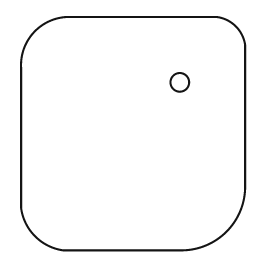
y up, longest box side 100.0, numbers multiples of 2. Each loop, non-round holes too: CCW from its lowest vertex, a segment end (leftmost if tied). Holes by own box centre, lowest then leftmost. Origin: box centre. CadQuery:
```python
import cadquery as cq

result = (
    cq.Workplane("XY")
    .moveTo(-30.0, -50.0)
    .lineTo(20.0, -50.0)
    .threePointArc((40.0, -42.0), (48.0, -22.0))
    .lineTo(48.0, 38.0)
    .threePointArc((44.0, 46.0), (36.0, 50.0))
    .lineTo(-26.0, 50.0)
    .threePointArc((-42.0, 44.0), (-48.0, 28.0))
    .lineTo(-48.0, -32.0)
    .threePointArc((-42.0, -44.0), (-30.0, -50.0))
    .close()
    .moveTo(20.0, 22.0)
    .circle(4.0)
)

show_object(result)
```